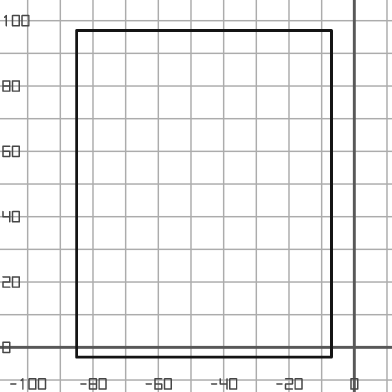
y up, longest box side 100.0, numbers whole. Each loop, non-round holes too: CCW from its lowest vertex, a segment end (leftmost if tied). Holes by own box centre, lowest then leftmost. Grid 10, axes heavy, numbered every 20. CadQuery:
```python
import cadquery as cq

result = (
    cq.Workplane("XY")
    .moveTo(-85.0, -3.0)
    .lineTo(-7.0, -3.0)
    .lineTo(-7.0, 97.0)
    .lineTo(-85.0, 97.0)
    .close()
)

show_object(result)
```